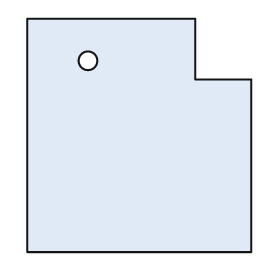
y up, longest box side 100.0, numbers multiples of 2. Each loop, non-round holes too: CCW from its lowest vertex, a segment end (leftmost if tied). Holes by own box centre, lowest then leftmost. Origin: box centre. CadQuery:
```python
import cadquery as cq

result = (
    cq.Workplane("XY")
    .moveTo(-48.0, -50.0)
    .lineTo(48.0, -50.0)
    .lineTo(48.0, 24.0)
    .lineTo(24.0, 24.0)
    .lineTo(24.0, 50.0)
    .lineTo(-48.0, 50.0)
    .close()
    .moveTo(-22.0, 32.0)
    .circle(4.0)
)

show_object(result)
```